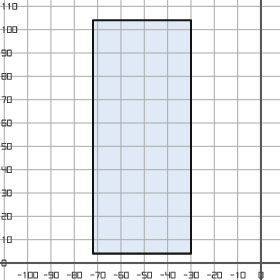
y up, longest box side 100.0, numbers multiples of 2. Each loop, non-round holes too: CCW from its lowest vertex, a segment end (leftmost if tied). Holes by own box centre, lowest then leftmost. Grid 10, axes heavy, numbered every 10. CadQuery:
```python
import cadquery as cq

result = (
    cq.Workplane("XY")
    .moveTo(-72.0, 4.0)
    .lineTo(-30.0, 4.0)
    .lineTo(-30.0, 104.0)
    .lineTo(-72.0, 104.0)
    .close()
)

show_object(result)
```